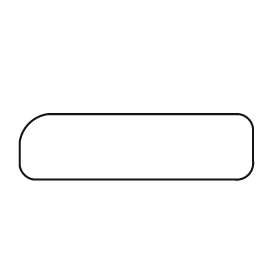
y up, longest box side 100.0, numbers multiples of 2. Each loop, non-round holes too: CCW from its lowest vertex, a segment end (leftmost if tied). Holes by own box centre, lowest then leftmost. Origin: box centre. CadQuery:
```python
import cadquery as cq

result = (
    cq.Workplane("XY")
    .moveTo(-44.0, -14.0)
    .lineTo(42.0, -14.0)
    .threePointArc((48.0, -12.0), (50.0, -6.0))
    .lineTo(50.0, 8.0)
    .threePointArc((48.0, 12.0), (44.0, 14.0))
    .lineTo(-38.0, 14.0)
    .threePointArc((-46.0, 10.0), (-50.0, 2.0))
    .lineTo(-50.0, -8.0)
    .threePointArc((-48.0, -12.0), (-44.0, -14.0))
    .close()
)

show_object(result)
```